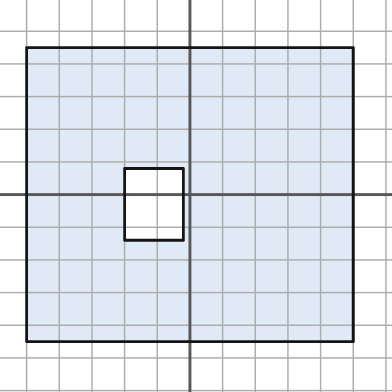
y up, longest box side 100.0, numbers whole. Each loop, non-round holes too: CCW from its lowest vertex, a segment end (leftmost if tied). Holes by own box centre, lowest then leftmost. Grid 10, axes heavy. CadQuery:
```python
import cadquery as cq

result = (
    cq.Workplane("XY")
    .moveTo(-50.0, -45.0)
    .lineTo(50.0, -45.0)
    .lineTo(50.0, 45.0)
    .lineTo(-50.0, 45.0)
    .close()
    .moveTo(-20.0, -14.0)
    .lineTo(-2.0, -14.0)
    .lineTo(-2.0, 8.0)
    .lineTo(-20.0, 8.0)
    .close()
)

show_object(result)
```